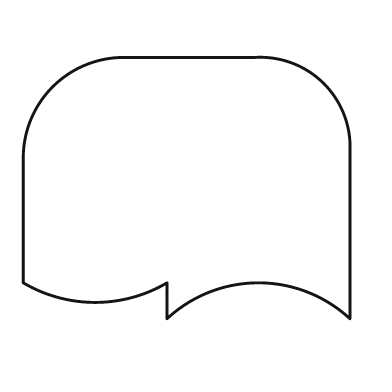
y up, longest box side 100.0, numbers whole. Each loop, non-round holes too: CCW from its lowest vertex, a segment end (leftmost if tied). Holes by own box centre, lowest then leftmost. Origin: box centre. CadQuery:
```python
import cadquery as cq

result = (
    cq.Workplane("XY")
    .moveTo(-6.0, -40.0)
    .threePointArc((22.0, -29.0), (50.0, -40.0))
    .lineTo(50.0, 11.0)
    .threePointArc((42.0, 32.0), (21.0, 40.0))
    .lineTo(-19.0, 40.0)
    .threePointArc((-41.0, 31.0), (-50.0, 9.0))
    .lineTo(-50.0, -29.0)
    .threePointArc((-28.0, -35.0), (-6.0, -29.0))
    .close()
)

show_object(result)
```